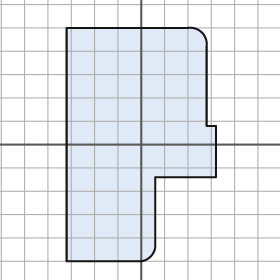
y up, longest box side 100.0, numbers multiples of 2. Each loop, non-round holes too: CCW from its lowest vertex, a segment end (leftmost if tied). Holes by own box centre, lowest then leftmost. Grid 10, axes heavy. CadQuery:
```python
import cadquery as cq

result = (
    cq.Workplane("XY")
    .moveTo(-32.0, -50.0)
    .lineTo(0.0, -50.0)
    .threePointArc((4.0, -48.0), (6.0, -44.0))
    .lineTo(6.0, -14.0)
    .lineTo(32.0, -14.0)
    .lineTo(32.0, 8.0)
    .lineTo(28.0, 8.0)
    .lineTo(28.0, 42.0)
    .threePointArc((26.0, 48.0), (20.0, 50.0))
    .lineTo(-32.0, 50.0)
    .close()
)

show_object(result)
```